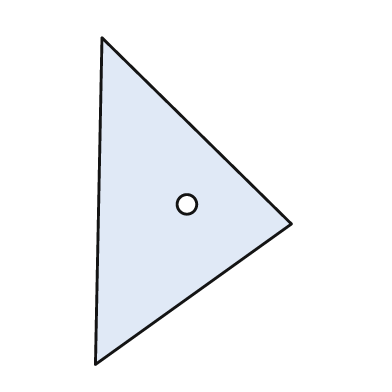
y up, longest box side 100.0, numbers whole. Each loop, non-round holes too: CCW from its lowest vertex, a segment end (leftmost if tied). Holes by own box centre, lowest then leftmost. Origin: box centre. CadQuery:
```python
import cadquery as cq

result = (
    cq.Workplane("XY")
    .moveTo(-30.0, -50.0)
    .lineTo(30.0, -7.0)
    .lineTo(-28.0, 50.0)
    .close()
    .moveTo(-2.0, -1.0)
    .circle(3.0)
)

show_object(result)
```